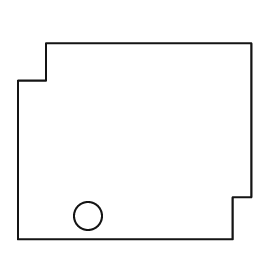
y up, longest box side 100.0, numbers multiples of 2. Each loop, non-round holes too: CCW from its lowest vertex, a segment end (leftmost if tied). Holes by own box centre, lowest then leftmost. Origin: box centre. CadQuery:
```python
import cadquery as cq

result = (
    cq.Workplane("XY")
    .moveTo(-50.0, -42.0)
    .lineTo(42.0, -42.0)
    .lineTo(42.0, -24.0)
    .lineTo(50.0, -24.0)
    .lineTo(50.0, 42.0)
    .lineTo(-38.0, 42.0)
    .lineTo(-38.0, 26.0)
    .lineTo(-50.0, 26.0)
    .close()
    .moveTo(-20.0, -32.0)
    .circle(6.0)
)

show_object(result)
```